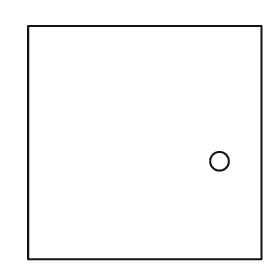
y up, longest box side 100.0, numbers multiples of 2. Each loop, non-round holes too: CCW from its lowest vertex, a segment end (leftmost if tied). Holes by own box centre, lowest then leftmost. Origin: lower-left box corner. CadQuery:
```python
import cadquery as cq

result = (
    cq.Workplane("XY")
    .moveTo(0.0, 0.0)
    .lineTo(100.0, 0.0)
    .lineTo(100.0, 100.0)
    .lineTo(0.0, 100.0)
    .close()
    .moveTo(82.0, 42.0)
    .circle(4.0)
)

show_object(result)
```